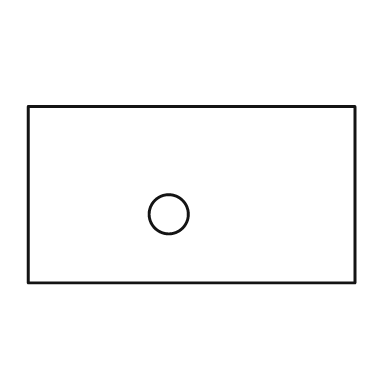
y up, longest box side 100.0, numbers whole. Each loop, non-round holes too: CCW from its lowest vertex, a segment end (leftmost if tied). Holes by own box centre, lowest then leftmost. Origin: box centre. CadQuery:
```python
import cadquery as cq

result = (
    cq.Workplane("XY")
    .moveTo(-50.0, -27.0)
    .lineTo(50.0, -27.0)
    .lineTo(50.0, 27.0)
    .lineTo(-50.0, 27.0)
    .close()
    .moveTo(-7.0, -6.0)
    .circle(6.0)
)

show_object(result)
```